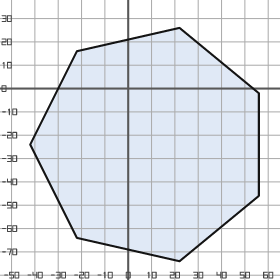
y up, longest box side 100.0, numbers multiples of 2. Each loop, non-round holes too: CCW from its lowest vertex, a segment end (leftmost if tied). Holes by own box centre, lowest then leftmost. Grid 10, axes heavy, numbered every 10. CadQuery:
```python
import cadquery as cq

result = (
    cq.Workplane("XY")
    .moveTo(22.0, -74.0)
    .lineTo(56.0, -46.0)
    .lineTo(56.0, -2.0)
    .lineTo(22.0, 26.0)
    .lineTo(-22.0, 16.0)
    .lineTo(-42.0, -24.0)
    .lineTo(-22.0, -64.0)
    .close()
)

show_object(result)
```